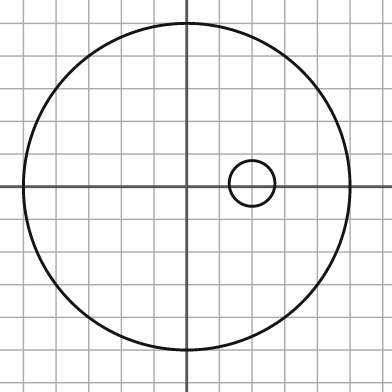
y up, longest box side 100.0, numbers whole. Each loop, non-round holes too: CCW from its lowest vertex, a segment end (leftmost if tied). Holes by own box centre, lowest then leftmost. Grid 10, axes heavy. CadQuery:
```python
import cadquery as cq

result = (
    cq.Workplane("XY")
    .moveTo(0.0, 0.0)
    .circle(50.0)
    .moveTo(20.0, 1.0)
    .circle(7.0)
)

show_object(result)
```